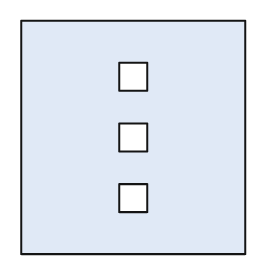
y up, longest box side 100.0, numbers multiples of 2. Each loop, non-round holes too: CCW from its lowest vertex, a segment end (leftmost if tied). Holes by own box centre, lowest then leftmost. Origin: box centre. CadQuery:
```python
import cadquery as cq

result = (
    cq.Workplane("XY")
    .moveTo(-48.0, -50.0)
    .lineTo(48.0, -50.0)
    .lineTo(48.0, 50.0)
    .lineTo(-48.0, 50.0)
    .close()
    .moveTo(-6.0, -32.0)
    .lineTo(6.0, -32.0)
    .lineTo(6.0, -20.0)
    .lineTo(-6.0, -20.0)
    .close()
    .moveTo(-6.0, -6.0)
    .lineTo(6.0, -6.0)
    .lineTo(6.0, 6.0)
    .lineTo(-6.0, 6.0)
    .close()
    .moveTo(-6.0, 20.0)
    .lineTo(6.0, 20.0)
    .lineTo(6.0, 32.0)
    .lineTo(-6.0, 32.0)
    .close()
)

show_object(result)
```